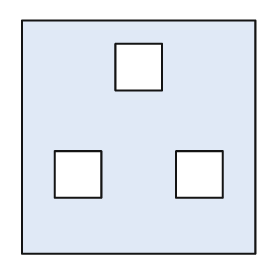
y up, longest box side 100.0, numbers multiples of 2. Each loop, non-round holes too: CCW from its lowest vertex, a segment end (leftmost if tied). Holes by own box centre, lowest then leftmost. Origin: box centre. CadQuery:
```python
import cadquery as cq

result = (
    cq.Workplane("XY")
    .moveTo(-50.0, -50.0)
    .lineTo(50.0, -50.0)
    .lineTo(50.0, 50.0)
    .lineTo(-50.0, 50.0)
    .close()
    .moveTo(-36.0, -26.0)
    .lineTo(-16.0, -26.0)
    .lineTo(-16.0, -6.0)
    .lineTo(-36.0, -6.0)
    .close()
    .moveTo(16.0, -26.0)
    .lineTo(36.0, -26.0)
    .lineTo(36.0, -6.0)
    .lineTo(16.0, -6.0)
    .close()
    .moveTo(-10.0, 20.0)
    .lineTo(10.0, 20.0)
    .lineTo(10.0, 40.0)
    .lineTo(-10.0, 40.0)
    .close()
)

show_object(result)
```